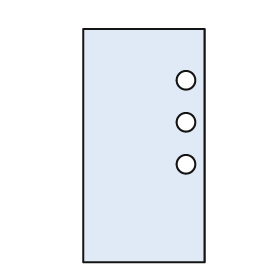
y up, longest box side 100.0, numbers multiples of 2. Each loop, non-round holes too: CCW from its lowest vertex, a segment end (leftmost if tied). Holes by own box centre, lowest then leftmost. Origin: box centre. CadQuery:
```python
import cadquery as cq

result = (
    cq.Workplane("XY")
    .moveTo(-26.0, -50.0)
    .lineTo(26.0, -50.0)
    .lineTo(26.0, 50.0)
    .lineTo(-26.0, 50.0)
    .close()
    .moveTo(18.0, -8.0)
    .circle(4.0)
    .moveTo(18.0, 10.0)
    .circle(4.0)
    .moveTo(18.0, 28.0)
    .circle(4.0)
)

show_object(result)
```